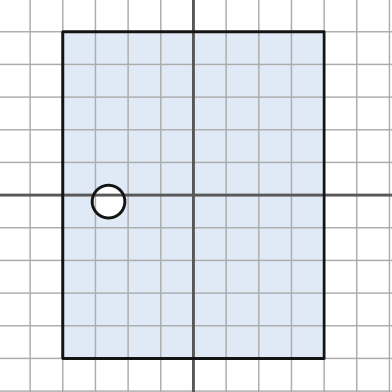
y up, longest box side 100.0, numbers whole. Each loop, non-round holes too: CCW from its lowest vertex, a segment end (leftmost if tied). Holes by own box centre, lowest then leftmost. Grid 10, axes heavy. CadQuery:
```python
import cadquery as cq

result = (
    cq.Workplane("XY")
    .moveTo(-40.0, -50.0)
    .lineTo(40.0, -50.0)
    .lineTo(40.0, 50.0)
    .lineTo(-40.0, 50.0)
    .close()
    .moveTo(-26.0, -2.0)
    .circle(5.0)
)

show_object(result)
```